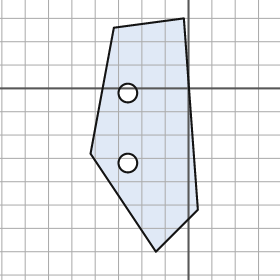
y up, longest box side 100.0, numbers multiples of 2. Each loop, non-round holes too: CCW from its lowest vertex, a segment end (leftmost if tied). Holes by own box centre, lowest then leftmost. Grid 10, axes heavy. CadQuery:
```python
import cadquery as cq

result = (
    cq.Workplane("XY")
    .moveTo(-14.0, -70.0)
    .lineTo(4.0, -52.0)
    .lineTo(-2.0, 30.0)
    .lineTo(-32.0, 26.0)
    .lineTo(-42.0, -28.0)
    .close()
    .moveTo(-26.0, -32.0)
    .circle(4.0)
    .moveTo(-26.0, -2.0)
    .circle(4.0)
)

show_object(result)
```